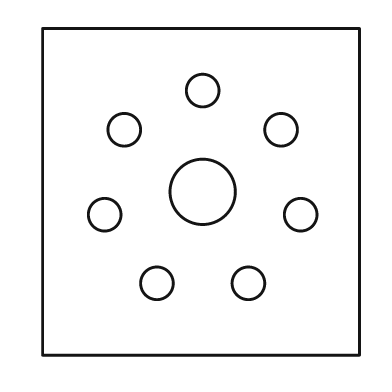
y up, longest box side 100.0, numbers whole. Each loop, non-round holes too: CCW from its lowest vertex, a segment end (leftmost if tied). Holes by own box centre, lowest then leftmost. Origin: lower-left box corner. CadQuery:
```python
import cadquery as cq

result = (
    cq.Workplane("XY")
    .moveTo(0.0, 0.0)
    .lineTo(97.0, 0.0)
    .lineTo(97.0, 100.0)
    .lineTo(0.0, 100.0)
    .close()
    .moveTo(35.0, 22.0)
    .circle(5.0)
    .moveTo(63.0, 22.0)
    .circle(5.0)
    .moveTo(19.0, 43.0)
    .circle(5.0)
    .moveTo(79.0, 43.0)
    .circle(5.0)
    .moveTo(49.0, 50.0)
    .circle(10.0)
    .moveTo(25.0, 69.0)
    .circle(5.0)
    .moveTo(73.0, 69.0)
    .circle(5.0)
    .moveTo(49.0, 81.0)
    .circle(5.0)
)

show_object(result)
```